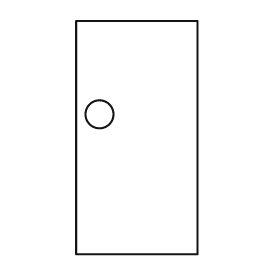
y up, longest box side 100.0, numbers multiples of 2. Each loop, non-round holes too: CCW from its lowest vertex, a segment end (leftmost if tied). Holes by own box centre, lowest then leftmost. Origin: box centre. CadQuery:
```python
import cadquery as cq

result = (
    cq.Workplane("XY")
    .moveTo(-26.0, -50.0)
    .lineTo(26.0, -50.0)
    .lineTo(26.0, 50.0)
    .lineTo(-26.0, 50.0)
    .close()
    .moveTo(-16.0, 10.0)
    .circle(6.0)
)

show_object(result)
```